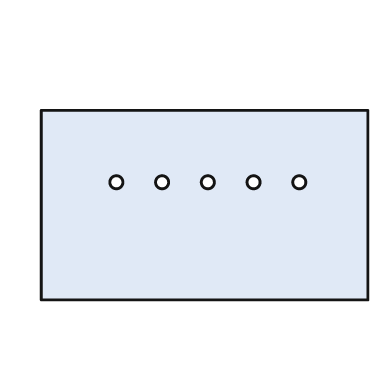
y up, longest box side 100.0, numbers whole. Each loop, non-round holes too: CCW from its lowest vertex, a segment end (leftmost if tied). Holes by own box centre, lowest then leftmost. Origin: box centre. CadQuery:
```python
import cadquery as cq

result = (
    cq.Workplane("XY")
    .moveTo(-50.0, -29.0)
    .lineTo(50.0, -29.0)
    .lineTo(50.0, 29.0)
    .lineTo(-50.0, 29.0)
    .close()
    .moveTo(-27.0, 7.0)
    .circle(2.0)
    .moveTo(-13.0, 7.0)
    .circle(2.0)
    .moveTo(1.0, 7.0)
    .circle(2.0)
    .moveTo(15.0, 7.0)
    .circle(2.0)
    .moveTo(29.0, 7.0)
    .circle(2.0)
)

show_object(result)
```